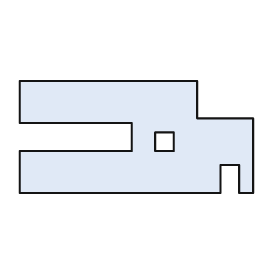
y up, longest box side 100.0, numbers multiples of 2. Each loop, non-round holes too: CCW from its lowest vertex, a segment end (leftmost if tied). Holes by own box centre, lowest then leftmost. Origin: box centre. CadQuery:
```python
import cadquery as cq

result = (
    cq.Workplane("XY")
    .moveTo(-50.0, -24.0)
    .lineTo(36.0, -24.0)
    .lineTo(36.0, -12.0)
    .lineTo(44.0, -12.0)
    .lineTo(44.0, -24.0)
    .lineTo(50.0, -24.0)
    .lineTo(50.0, 8.0)
    .lineTo(26.0, 8.0)
    .lineTo(26.0, 24.0)
    .lineTo(-50.0, 24.0)
    .lineTo(-50.0, 6.0)
    .lineTo(-2.0, 6.0)
    .lineTo(-2.0, -6.0)
    .lineTo(-50.0, -6.0)
    .close()
    .moveTo(8.0, -6.0)
    .lineTo(16.0, -6.0)
    .lineTo(16.0, 2.0)
    .lineTo(8.0, 2.0)
    .close()
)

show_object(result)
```